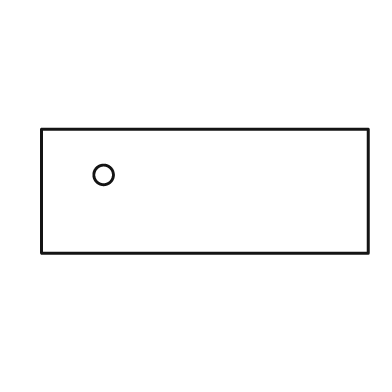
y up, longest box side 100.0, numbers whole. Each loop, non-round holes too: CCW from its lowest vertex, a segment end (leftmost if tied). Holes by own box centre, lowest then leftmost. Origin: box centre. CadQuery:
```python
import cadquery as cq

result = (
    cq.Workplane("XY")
    .moveTo(-50.0, -19.0)
    .lineTo(50.0, -19.0)
    .lineTo(50.0, 19.0)
    .lineTo(-50.0, 19.0)
    .close()
    .moveTo(-31.0, 5.0)
    .circle(3.0)
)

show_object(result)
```